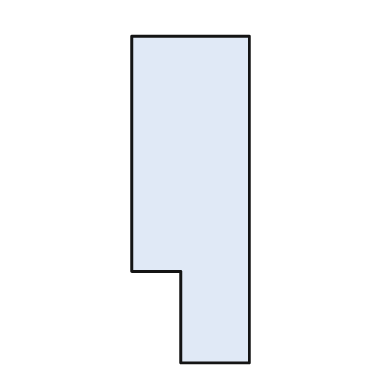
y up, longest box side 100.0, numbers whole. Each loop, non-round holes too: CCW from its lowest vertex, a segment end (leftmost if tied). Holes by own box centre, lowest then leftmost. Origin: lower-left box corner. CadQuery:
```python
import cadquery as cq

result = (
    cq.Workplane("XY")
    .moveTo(15.0, 0.0)
    .lineTo(36.0, 0.0)
    .lineTo(36.0, 100.0)
    .lineTo(0.0, 100.0)
    .lineTo(0.0, 28.0)
    .lineTo(15.0, 28.0)
    .close()
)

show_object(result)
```